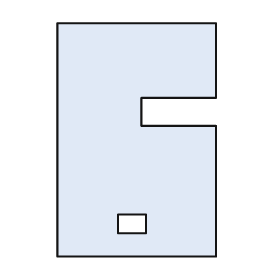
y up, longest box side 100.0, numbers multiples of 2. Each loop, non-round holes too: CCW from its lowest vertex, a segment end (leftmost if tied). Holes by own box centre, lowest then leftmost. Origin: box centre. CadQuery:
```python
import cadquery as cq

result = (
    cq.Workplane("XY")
    .moveTo(-34.0, -50.0)
    .lineTo(34.0, -50.0)
    .lineTo(34.0, 6.0)
    .lineTo(2.0, 6.0)
    .lineTo(2.0, 18.0)
    .lineTo(34.0, 18.0)
    .lineTo(34.0, 50.0)
    .lineTo(-34.0, 50.0)
    .close()
    .moveTo(-8.0, -40.0)
    .lineTo(4.0, -40.0)
    .lineTo(4.0, -32.0)
    .lineTo(-8.0, -32.0)
    .close()
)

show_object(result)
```